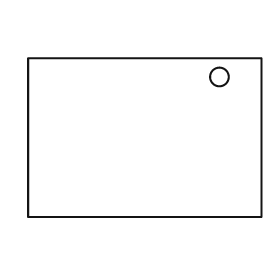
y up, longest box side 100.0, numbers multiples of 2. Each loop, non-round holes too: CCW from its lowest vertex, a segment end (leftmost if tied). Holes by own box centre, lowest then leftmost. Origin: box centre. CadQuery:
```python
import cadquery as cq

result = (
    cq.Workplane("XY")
    .moveTo(-50.0, -34.0)
    .lineTo(50.0, -34.0)
    .lineTo(50.0, 34.0)
    .lineTo(-50.0, 34.0)
    .close()
    .moveTo(32.0, 26.0)
    .circle(4.0)
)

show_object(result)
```